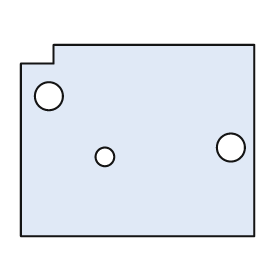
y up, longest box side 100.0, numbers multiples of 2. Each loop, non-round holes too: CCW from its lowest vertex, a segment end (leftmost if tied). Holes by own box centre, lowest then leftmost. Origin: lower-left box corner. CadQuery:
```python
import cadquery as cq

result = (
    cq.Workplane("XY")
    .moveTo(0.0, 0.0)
    .lineTo(100.0, 0.0)
    .lineTo(100.0, 82.0)
    .lineTo(14.0, 82.0)
    .lineTo(14.0, 74.0)
    .lineTo(0.0, 74.0)
    .close()
    .moveTo(36.0, 34.0)
    .circle(4.0)
    .moveTo(90.0, 38.0)
    .circle(6.0)
    .moveTo(12.0, 60.0)
    .circle(6.0)
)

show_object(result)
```